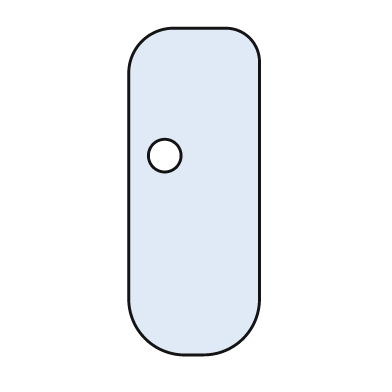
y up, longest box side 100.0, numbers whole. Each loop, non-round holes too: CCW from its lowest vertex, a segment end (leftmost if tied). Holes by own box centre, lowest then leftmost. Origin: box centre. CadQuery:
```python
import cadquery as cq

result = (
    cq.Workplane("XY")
    .moveTo(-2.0, -50.0)
    .lineTo(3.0, -50.0)
    .threePointArc((15.0, -45.0), (20.0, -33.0))
    .lineTo(20.0, 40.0)
    .threePointArc((17.0, 47.0), (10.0, 50.0))
    .lineTo(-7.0, 50.0)
    .threePointArc((-16.0, 46.0), (-20.0, 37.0))
    .lineTo(-20.0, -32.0)
    .threePointArc((-15.0, -45.0), (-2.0, -50.0))
    .close()
    .moveTo(-9.0, 11.0)
    .circle(5.0)
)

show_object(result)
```